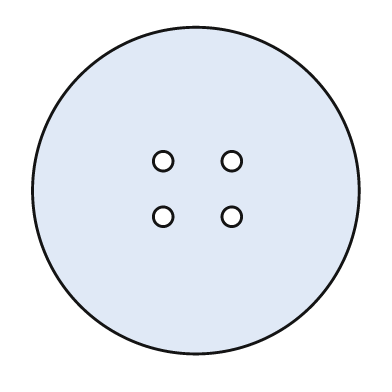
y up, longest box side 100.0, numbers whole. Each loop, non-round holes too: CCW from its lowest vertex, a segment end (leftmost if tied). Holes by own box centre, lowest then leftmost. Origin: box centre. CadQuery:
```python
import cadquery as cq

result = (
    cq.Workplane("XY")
    .moveTo(0.0, 0.0)
    .circle(50.0)
    .moveTo(-10.0, -8.0)
    .circle(3.0)
    .moveTo(11.0, -8.0)
    .circle(3.0)
    .moveTo(-10.0, 9.0)
    .circle(3.0)
    .moveTo(11.0, 9.0)
    .circle(3.0)
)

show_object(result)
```